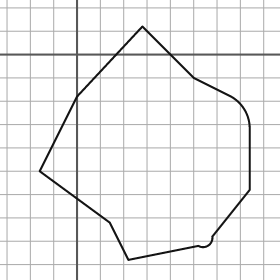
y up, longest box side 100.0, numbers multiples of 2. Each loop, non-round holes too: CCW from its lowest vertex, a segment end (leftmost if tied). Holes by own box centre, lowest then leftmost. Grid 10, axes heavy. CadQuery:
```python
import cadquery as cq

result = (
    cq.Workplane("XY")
    .moveTo(22.0, -88.0)
    .lineTo(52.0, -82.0)
    .threePointArc((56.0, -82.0), (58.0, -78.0))
    .lineTo(74.0, -58.0)
    .lineTo(74.0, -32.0)
    .threePointArc((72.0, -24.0), (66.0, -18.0))
    .lineTo(50.0, -10.0)
    .lineTo(28.0, 12.0)
    .lineTo(0.0, -18.0)
    .lineTo(-16.0, -50.0)
    .lineTo(14.0, -72.0)
    .close()
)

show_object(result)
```